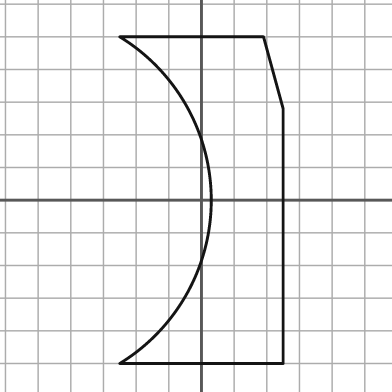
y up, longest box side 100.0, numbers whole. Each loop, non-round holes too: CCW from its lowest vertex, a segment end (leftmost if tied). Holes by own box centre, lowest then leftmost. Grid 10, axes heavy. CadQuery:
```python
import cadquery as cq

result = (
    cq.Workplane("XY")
    .moveTo(-25.0, -50.0)
    .lineTo(25.0, -50.0)
    .lineTo(25.0, 28.0)
    .lineTo(19.0, 50.0)
    .lineTo(-25.0, 50.0)
    .threePointArc((3.0, 0.0), (-25.0, -50.0))
    .close()
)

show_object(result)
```